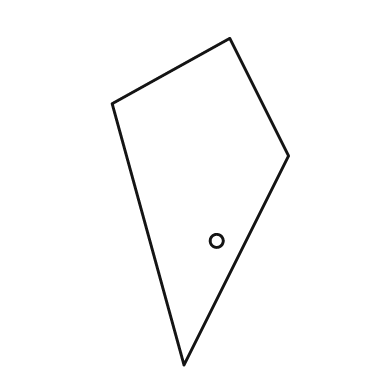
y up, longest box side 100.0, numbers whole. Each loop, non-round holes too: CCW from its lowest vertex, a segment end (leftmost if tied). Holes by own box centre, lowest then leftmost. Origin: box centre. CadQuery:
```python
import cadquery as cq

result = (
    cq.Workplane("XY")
    .moveTo(-5.0, -50.0)
    .lineTo(27.0, 14.0)
    .lineTo(9.0, 50.0)
    .lineTo(-27.0, 30.0)
    .close()
    .moveTo(5.0, -12.0)
    .circle(2.0)
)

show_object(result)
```